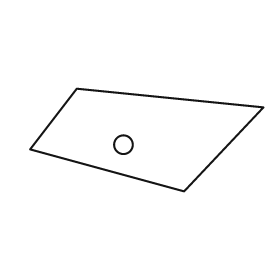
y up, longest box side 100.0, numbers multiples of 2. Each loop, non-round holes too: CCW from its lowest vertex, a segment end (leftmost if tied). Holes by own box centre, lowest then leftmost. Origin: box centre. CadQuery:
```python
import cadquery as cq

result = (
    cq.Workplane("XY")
    .moveTo(16.0, -22.0)
    .lineTo(50.0, 14.0)
    .lineTo(-30.0, 22.0)
    .lineTo(-50.0, -4.0)
    .close()
    .moveTo(-10.0, -2.0)
    .circle(4.0)
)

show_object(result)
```